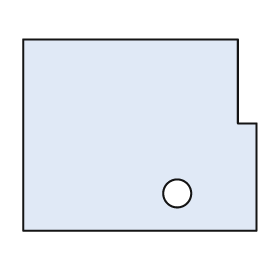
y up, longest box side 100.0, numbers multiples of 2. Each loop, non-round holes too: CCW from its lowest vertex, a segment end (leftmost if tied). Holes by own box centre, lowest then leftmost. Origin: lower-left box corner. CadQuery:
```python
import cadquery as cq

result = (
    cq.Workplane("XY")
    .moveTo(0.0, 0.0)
    .lineTo(100.0, 0.0)
    .lineTo(100.0, 46.0)
    .lineTo(92.0, 46.0)
    .lineTo(92.0, 82.0)
    .lineTo(0.0, 82.0)
    .close()
    .moveTo(66.0, 16.0)
    .circle(6.0)
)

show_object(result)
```